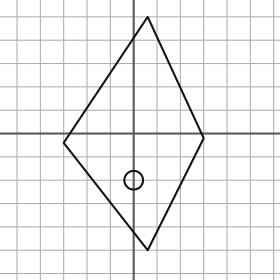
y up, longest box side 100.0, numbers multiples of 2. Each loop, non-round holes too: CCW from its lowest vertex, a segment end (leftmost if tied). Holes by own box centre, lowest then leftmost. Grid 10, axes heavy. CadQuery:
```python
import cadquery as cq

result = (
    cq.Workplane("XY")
    .moveTo(6.0, -50.0)
    .lineTo(30.0, -2.0)
    .lineTo(6.0, 50.0)
    .lineTo(-30.0, -4.0)
    .close()
    .moveTo(0.0, -20.0)
    .circle(4.0)
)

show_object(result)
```